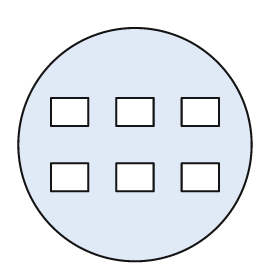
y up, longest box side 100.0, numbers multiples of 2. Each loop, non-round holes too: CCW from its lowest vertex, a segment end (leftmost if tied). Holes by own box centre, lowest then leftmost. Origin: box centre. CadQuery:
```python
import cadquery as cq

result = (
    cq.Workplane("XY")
    .moveTo(0.0, 0.0)
    .circle(50.0)
    .moveTo(-36.0, -20.0)
    .lineTo(-20.0, -20.0)
    .lineTo(-20.0, -8.0)
    .lineTo(-36.0, -8.0)
    .close()
    .moveTo(-8.0, -20.0)
    .lineTo(8.0, -20.0)
    .lineTo(8.0, -8.0)
    .lineTo(-8.0, -8.0)
    .close()
    .moveTo(20.0, -20.0)
    .lineTo(36.0, -20.0)
    .lineTo(36.0, -8.0)
    .lineTo(20.0, -8.0)
    .close()
    .moveTo(-36.0, 8.0)
    .lineTo(-20.0, 8.0)
    .lineTo(-20.0, 20.0)
    .lineTo(-36.0, 20.0)
    .close()
    .moveTo(-8.0, 8.0)
    .lineTo(8.0, 8.0)
    .lineTo(8.0, 20.0)
    .lineTo(-8.0, 20.0)
    .close()
    .moveTo(20.0, 8.0)
    .lineTo(36.0, 8.0)
    .lineTo(36.0, 20.0)
    .lineTo(20.0, 20.0)
    .close()
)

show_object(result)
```